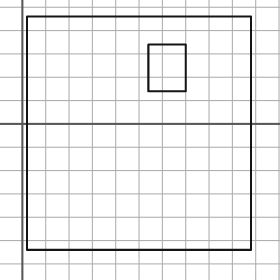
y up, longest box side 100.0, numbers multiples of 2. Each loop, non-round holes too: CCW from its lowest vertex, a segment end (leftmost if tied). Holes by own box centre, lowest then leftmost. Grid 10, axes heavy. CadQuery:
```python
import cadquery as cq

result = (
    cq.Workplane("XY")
    .moveTo(2.0, -54.0)
    .lineTo(98.0, -54.0)
    .lineTo(98.0, 46.0)
    .lineTo(2.0, 46.0)
    .close()
    .moveTo(54.0, 14.0)
    .lineTo(70.0, 14.0)
    .lineTo(70.0, 34.0)
    .lineTo(54.0, 34.0)
    .close()
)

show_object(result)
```